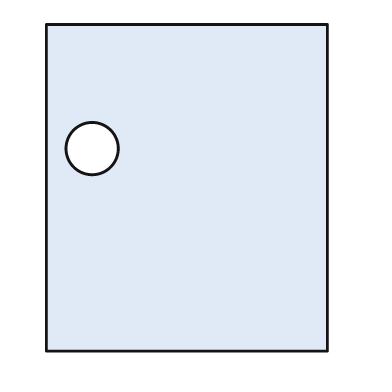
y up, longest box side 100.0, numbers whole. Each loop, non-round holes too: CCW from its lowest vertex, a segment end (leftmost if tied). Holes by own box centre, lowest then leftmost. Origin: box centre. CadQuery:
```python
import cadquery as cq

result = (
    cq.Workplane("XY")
    .moveTo(-43.0, -50.0)
    .lineTo(43.0, -50.0)
    .lineTo(43.0, 50.0)
    .lineTo(-43.0, 50.0)
    .close()
    .moveTo(-29.0, 12.0)
    .circle(8.0)
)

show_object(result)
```